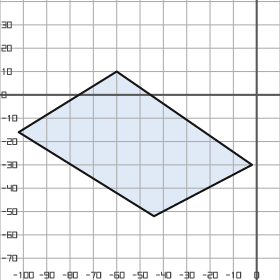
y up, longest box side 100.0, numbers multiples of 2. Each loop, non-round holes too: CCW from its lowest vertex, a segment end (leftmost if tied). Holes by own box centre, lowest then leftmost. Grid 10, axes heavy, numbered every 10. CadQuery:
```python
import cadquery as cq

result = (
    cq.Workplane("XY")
    .moveTo(-44.0, -52.0)
    .lineTo(-2.0, -30.0)
    .lineTo(-60.0, 10.0)
    .lineTo(-102.0, -16.0)
    .close()
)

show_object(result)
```